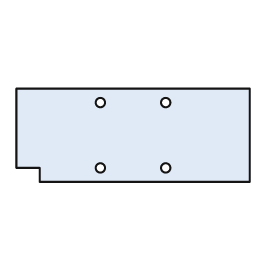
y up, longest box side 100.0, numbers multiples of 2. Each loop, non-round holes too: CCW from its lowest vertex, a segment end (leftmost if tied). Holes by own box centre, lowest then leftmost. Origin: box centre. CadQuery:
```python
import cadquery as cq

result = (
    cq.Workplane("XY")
    .moveTo(-40.0, -20.0)
    .lineTo(50.0, -20.0)
    .lineTo(50.0, 20.0)
    .lineTo(-50.0, 20.0)
    .lineTo(-50.0, -14.0)
    .lineTo(-40.0, -14.0)
    .close()
    .moveTo(-14.0, -14.0)
    .circle(2.0)
    .moveTo(14.0, -14.0)
    .circle(2.0)
    .moveTo(-14.0, 14.0)
    .circle(2.0)
    .moveTo(14.0, 14.0)
    .circle(2.0)
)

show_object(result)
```